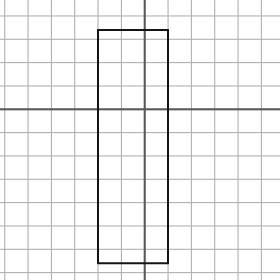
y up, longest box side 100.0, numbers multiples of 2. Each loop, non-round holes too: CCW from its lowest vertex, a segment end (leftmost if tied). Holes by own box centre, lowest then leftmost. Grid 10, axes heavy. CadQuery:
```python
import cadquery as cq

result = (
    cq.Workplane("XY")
    .moveTo(-20.0, -66.0)
    .lineTo(10.0, -66.0)
    .lineTo(10.0, 34.0)
    .lineTo(-20.0, 34.0)
    .close()
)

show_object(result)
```